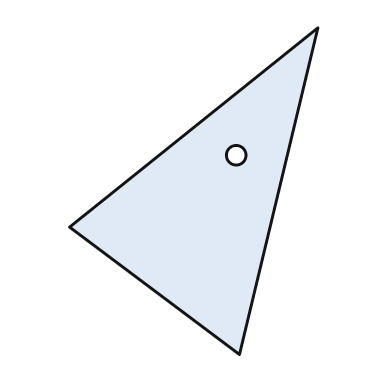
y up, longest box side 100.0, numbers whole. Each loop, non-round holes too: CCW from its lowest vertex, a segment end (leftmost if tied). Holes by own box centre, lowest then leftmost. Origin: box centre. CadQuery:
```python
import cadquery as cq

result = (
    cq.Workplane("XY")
    .moveTo(14.0, -50.0)
    .lineTo(38.0, 50.0)
    .lineTo(-38.0, -11.0)
    .close()
    .moveTo(13.0, 11.0)
    .circle(3.0)
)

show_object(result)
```